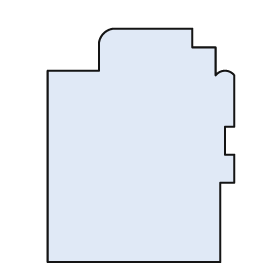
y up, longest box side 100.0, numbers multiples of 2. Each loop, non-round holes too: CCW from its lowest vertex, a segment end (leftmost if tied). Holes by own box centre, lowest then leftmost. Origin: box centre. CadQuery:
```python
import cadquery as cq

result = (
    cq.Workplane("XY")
    .moveTo(-40.0, -50.0)
    .lineTo(34.0, -50.0)
    .lineTo(34.0, -16.0)
    .lineTo(40.0, -16.0)
    .lineTo(40.0, -4.0)
    .lineTo(36.0, -4.0)
    .lineTo(36.0, 8.0)
    .lineTo(40.0, 8.0)
    .lineTo(40.0, 30.0)
    .threePointArc((36.0, 32.0), (32.0, 30.0))
    .lineTo(32.0, 42.0)
    .lineTo(22.0, 42.0)
    .lineTo(22.0, 50.0)
    .lineTo(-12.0, 50.0)
    .threePointArc((-16.0, 48.0), (-18.0, 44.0))
    .lineTo(-18.0, 32.0)
    .lineTo(-40.0, 32.0)
    .close()
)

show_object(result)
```